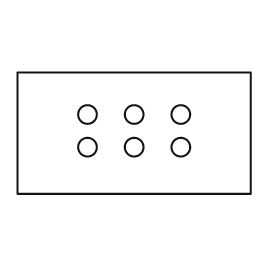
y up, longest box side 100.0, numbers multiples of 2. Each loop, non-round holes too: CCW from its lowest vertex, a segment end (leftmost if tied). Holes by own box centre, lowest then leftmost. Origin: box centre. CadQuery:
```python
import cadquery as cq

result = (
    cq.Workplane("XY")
    .moveTo(-50.0, -26.0)
    .lineTo(50.0, -26.0)
    .lineTo(50.0, 26.0)
    .lineTo(-50.0, 26.0)
    .close()
    .moveTo(-20.0, -6.0)
    .circle(4.0)
    .moveTo(0.0, -6.0)
    .circle(4.0)
    .moveTo(20.0, -6.0)
    .circle(4.0)
    .moveTo(-20.0, 8.0)
    .circle(4.0)
    .moveTo(0.0, 8.0)
    .circle(4.0)
    .moveTo(20.0, 8.0)
    .circle(4.0)
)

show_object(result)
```